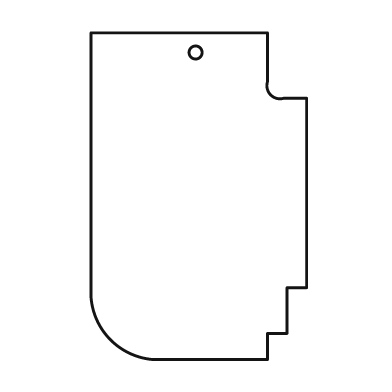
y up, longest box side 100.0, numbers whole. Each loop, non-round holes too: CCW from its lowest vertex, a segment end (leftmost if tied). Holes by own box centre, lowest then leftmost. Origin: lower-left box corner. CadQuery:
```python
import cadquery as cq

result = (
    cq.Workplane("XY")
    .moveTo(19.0, 0.0)
    .lineTo(54.0, 0.0)
    .lineTo(54.0, 8.0)
    .lineTo(60.0, 8.0)
    .lineTo(60.0, 22.0)
    .lineTo(66.0, 22.0)
    .lineTo(66.0, 80.0)
    .lineTo(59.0, 80.0)
    .threePointArc((55.0, 81.0), (54.0, 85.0))
    .lineTo(54.0, 100.0)
    .lineTo(0.0, 100.0)
    .lineTo(0.0, 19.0)
    .threePointArc((6.0, 6.0), (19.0, 0.0))
    .close()
    .moveTo(32.0, 94.0)
    .circle(2.0)
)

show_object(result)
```